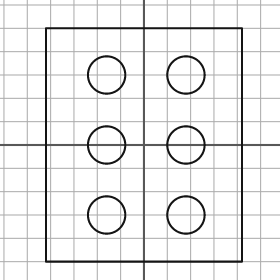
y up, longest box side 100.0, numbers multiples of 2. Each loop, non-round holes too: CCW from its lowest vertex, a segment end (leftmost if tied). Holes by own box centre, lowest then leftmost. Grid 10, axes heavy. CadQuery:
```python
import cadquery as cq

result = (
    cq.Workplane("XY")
    .moveTo(-42.0, -50.0)
    .lineTo(42.0, -50.0)
    .lineTo(42.0, 50.0)
    .lineTo(-42.0, 50.0)
    .close()
    .moveTo(-16.0, -30.0)
    .circle(8.0)
    .moveTo(18.0, -30.0)
    .circle(8.0)
    .moveTo(-16.0, 0.0)
    .circle(8.0)
    .moveTo(18.0, 0.0)
    .circle(8.0)
    .moveTo(-16.0, 30.0)
    .circle(8.0)
    .moveTo(18.0, 30.0)
    .circle(8.0)
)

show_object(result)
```